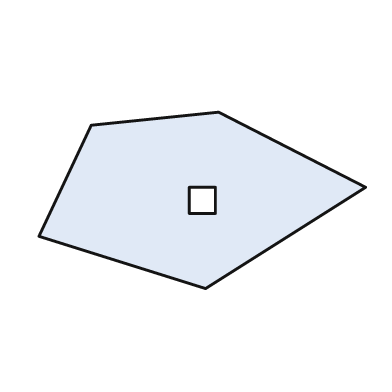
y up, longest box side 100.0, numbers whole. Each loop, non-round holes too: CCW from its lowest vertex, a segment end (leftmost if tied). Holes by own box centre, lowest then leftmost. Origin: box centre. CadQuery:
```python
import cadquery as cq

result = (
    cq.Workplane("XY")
    .moveTo(1.0, -27.0)
    .lineTo(50.0, 4.0)
    .lineTo(5.0, 27.0)
    .lineTo(-34.0, 23.0)
    .lineTo(-50.0, -11.0)
    .close()
    .moveTo(-4.0, -4.0)
    .lineTo(4.0, -4.0)
    .lineTo(4.0, 4.0)
    .lineTo(-4.0, 4.0)
    .close()
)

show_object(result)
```